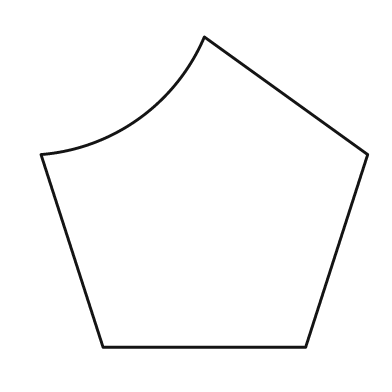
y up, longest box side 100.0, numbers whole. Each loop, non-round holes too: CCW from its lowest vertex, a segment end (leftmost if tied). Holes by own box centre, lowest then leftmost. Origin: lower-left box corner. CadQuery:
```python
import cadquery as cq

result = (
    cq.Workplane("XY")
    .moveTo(19.0, 0.0)
    .lineTo(81.0, 0.0)
    .lineTo(100.0, 59.0)
    .lineTo(50.0, 95.0)
    .threePointArc((30.0, 70.0), (0.0, 59.0))
    .close()
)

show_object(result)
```